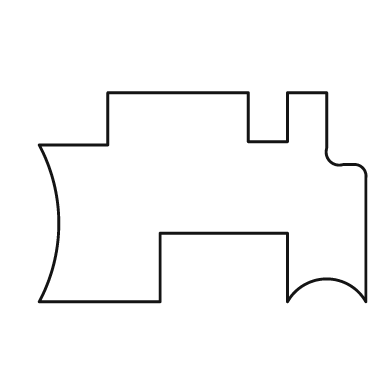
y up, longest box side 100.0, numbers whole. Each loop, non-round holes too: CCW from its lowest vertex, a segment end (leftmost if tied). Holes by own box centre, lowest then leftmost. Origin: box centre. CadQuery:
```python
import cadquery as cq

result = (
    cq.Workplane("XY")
    .moveTo(-50.0, -32.0)
    .lineTo(-13.0, -32.0)
    .lineTo(-13.0, -11.0)
    .lineTo(26.0, -11.0)
    .lineTo(26.0, -32.0)
    .threePointArc((38.0, -25.0), (50.0, -32.0))
    .lineTo(50.0, 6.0)
    .threePointArc((49.0, 9.0), (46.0, 10.0))
    .lineTo(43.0, 10.0)
    .threePointArc((39.0, 11.0), (38.0, 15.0))
    .lineTo(38.0, 32.0)
    .lineTo(26.0, 32.0)
    .lineTo(26.0, 17.0)
    .lineTo(14.0, 17.0)
    .lineTo(14.0, 32.0)
    .lineTo(-29.0, 32.0)
    .lineTo(-29.0, 16.0)
    .lineTo(-50.0, 16.0)
    .threePointArc((-44.0, -8.0), (-50.0, -32.0))
    .close()
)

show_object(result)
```